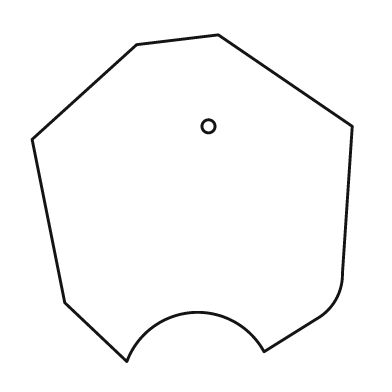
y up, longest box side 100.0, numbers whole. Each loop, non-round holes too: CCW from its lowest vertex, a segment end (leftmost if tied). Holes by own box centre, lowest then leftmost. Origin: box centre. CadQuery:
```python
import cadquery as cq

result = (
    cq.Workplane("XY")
    .moveTo(-20.0, -50.0)
    .threePointArc((0.0, -35.0), (22.0, -47.0))
    .lineTo(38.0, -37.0)
    .threePointArc((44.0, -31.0), (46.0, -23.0))
    .lineTo(49.0, 22.0)
    .lineTo(8.0, 50.0)
    .lineTo(-17.0, 47.0)
    .lineTo(-49.0, 18.0)
    .lineTo(-39.0, -32.0)
    .close()
    .moveTo(5.0, 22.0)
    .circle(2.0)
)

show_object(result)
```